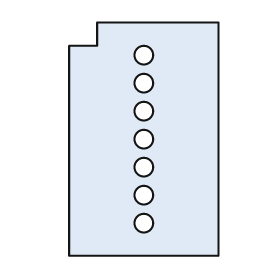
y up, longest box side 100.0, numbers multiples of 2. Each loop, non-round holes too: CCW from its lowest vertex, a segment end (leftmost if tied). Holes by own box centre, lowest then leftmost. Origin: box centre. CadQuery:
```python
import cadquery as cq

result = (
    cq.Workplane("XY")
    .moveTo(-32.0, -50.0)
    .lineTo(32.0, -50.0)
    .lineTo(32.0, 50.0)
    .lineTo(-20.0, 50.0)
    .lineTo(-20.0, 40.0)
    .lineTo(-32.0, 40.0)
    .close()
    .moveTo(0.0, -36.0)
    .circle(4.0)
    .moveTo(0.0, -24.0)
    .circle(4.0)
    .moveTo(0.0, -12.0)
    .circle(4.0)
    .moveTo(0.0, 0.0)
    .circle(4.0)
    .moveTo(0.0, 12.0)
    .circle(4.0)
    .moveTo(0.0, 24.0)
    .circle(4.0)
    .moveTo(0.0, 36.0)
    .circle(4.0)
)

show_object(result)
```